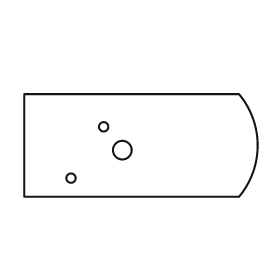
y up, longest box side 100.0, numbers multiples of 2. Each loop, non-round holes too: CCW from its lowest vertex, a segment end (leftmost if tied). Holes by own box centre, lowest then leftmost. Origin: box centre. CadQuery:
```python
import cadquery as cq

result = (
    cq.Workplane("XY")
    .moveTo(-50.0, -22.0)
    .lineTo(42.0, -22.0)
    .threePointArc((50.0, 0.0), (42.0, 22.0))
    .lineTo(-50.0, 22.0)
    .close()
    .moveTo(-30.0, -14.0)
    .circle(2.0)
    .moveTo(-8.0, -2.0)
    .circle(4.0)
    .moveTo(-16.0, 8.0)
    .circle(2.0)
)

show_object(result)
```